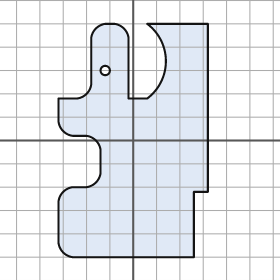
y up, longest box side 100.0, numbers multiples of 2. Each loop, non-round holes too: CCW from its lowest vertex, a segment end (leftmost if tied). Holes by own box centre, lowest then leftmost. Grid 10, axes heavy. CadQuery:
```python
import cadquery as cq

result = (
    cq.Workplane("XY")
    .moveTo(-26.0, -50.0)
    .lineTo(26.0, -50.0)
    .lineTo(26.0, -22.0)
    .lineTo(32.0, -22.0)
    .lineTo(32.0, 50.0)
    .lineTo(6.0, 50.0)
    .threePointArc((14.0, 34.0), (6.0, 18.0))
    .lineTo(-2.0, 18.0)
    .lineTo(-2.0, 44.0)
    .threePointArc((-4.0, 48.0), (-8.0, 50.0))
    .lineTo(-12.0, 50.0)
    .threePointArc((-16.0, 48.0), (-18.0, 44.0))
    .lineTo(-18.0, 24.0)
    .threePointArc((-20.0, 20.0), (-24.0, 18.0))
    .lineTo(-32.0, 18.0)
    .lineTo(-32.0, 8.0)
    .threePointArc((-30.0, 4.0), (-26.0, 2.0))
    .lineTo(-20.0, 2.0)
    .threePointArc((-16.0, 0.0), (-14.0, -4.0))
    .lineTo(-14.0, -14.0)
    .threePointArc((-16.0, -18.0), (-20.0, -20.0))
    .lineTo(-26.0, -20.0)
    .threePointArc((-30.0, -22.0), (-32.0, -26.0))
    .lineTo(-32.0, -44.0)
    .threePointArc((-30.0, -48.0), (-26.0, -50.0))
    .close()
    .moveTo(-12.0, 30.0)
    .circle(2.0)
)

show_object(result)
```